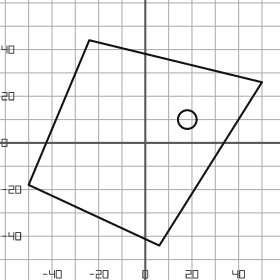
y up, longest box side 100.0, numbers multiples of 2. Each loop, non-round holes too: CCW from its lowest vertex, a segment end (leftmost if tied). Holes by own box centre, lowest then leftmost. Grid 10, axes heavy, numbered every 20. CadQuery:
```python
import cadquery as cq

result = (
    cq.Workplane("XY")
    .moveTo(6.0, -44.0)
    .lineTo(50.0, 26.0)
    .lineTo(-24.0, 44.0)
    .lineTo(-50.0, -18.0)
    .close()
    .moveTo(18.0, 10.0)
    .circle(4.0)
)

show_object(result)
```